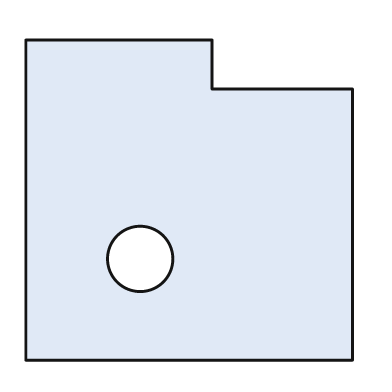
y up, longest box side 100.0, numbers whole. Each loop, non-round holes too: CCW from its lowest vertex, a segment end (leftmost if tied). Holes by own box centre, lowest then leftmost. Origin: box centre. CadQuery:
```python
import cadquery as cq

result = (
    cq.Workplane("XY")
    .moveTo(-50.0, -49.0)
    .lineTo(50.0, -49.0)
    .lineTo(50.0, 34.0)
    .lineTo(7.0, 34.0)
    .lineTo(7.0, 49.0)
    .lineTo(-50.0, 49.0)
    .close()
    .moveTo(-15.0, -18.0)
    .circle(10.0)
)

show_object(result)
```